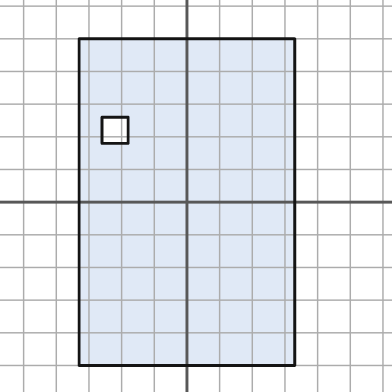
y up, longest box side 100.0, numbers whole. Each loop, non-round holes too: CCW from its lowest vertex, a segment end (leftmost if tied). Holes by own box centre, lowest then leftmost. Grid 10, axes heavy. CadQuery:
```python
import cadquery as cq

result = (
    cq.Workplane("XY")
    .moveTo(-33.0, -50.0)
    .lineTo(33.0, -50.0)
    .lineTo(33.0, 50.0)
    .lineTo(-33.0, 50.0)
    .close()
    .moveTo(-26.0, 18.0)
    .lineTo(-18.0, 18.0)
    .lineTo(-18.0, 26.0)
    .lineTo(-26.0, 26.0)
    .close()
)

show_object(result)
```